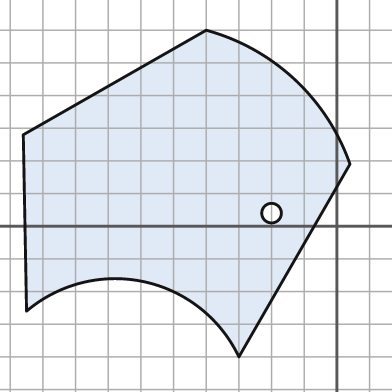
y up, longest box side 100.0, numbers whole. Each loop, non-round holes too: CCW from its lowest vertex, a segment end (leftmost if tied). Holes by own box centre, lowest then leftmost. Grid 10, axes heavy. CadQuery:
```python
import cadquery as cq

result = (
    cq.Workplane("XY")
    .moveTo(-30.0, -40.0)
    .lineTo(4.0, 19.0)
    .threePointArc((-13.0, 45.0), (-40.0, 60.0))
    .lineTo(-96.0, 28.0)
    .lineTo(-95.0, -26.0)
    .threePointArc((-59.0, -17.0), (-30.0, -40.0))
    .close()
    .moveTo(-20.0, 4.0)
    .circle(3.0)
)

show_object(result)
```